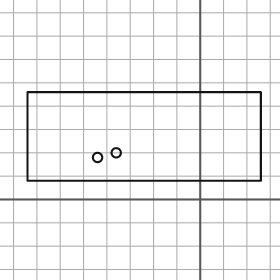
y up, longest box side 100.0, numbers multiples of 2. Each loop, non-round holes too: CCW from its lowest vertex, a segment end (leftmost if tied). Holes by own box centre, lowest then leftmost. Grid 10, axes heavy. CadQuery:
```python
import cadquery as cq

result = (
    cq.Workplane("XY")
    .moveTo(-74.0, 8.0)
    .lineTo(26.0, 8.0)
    .lineTo(26.0, 46.0)
    .lineTo(-74.0, 46.0)
    .close()
    .moveTo(-44.0, 18.0)
    .circle(2.0)
    .moveTo(-36.0, 20.0)
    .circle(2.0)
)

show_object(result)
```